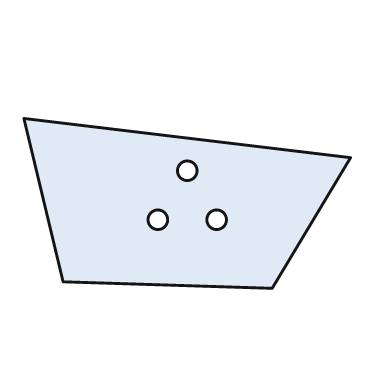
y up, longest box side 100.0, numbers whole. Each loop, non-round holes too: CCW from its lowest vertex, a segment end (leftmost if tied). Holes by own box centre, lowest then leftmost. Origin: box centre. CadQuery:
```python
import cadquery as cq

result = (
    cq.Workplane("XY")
    .moveTo(26.0, -26.0)
    .lineTo(50.0, 14.0)
    .lineTo(-50.0, 26.0)
    .lineTo(-38.0, -24.0)
    .close()
    .moveTo(-9.0, -5.0)
    .circle(3.0)
    .moveTo(9.0, -5.0)
    .circle(3.0)
    .moveTo(0.0, 10.0)
    .circle(3.0)
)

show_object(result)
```